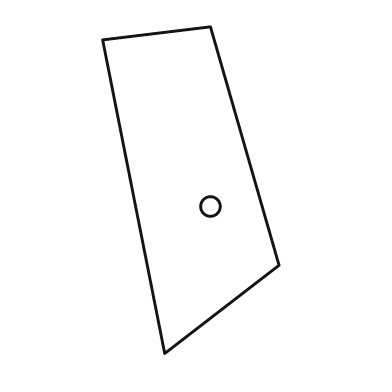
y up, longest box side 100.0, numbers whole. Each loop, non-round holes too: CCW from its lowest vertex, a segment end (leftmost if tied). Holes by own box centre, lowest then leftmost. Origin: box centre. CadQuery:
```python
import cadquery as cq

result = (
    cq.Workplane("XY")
    .moveTo(-8.0, -50.0)
    .lineTo(27.0, -23.0)
    .lineTo(6.0, 50.0)
    .lineTo(-27.0, 46.0)
    .close()
    .moveTo(6.0, -5.0)
    .circle(3.0)
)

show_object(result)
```